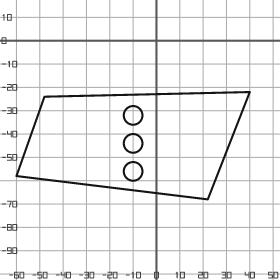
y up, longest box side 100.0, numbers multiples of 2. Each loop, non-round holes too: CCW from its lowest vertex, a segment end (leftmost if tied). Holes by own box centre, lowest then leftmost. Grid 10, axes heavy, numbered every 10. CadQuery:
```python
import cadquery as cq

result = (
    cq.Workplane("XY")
    .moveTo(22.0, -68.0)
    .lineTo(40.0, -22.0)
    .lineTo(-48.0, -24.0)
    .lineTo(-60.0, -58.0)
    .close()
    .moveTo(-10.0, -56.0)
    .circle(4.0)
    .moveTo(-10.0, -44.0)
    .circle(4.0)
    .moveTo(-10.0, -32.0)
    .circle(4.0)
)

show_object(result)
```